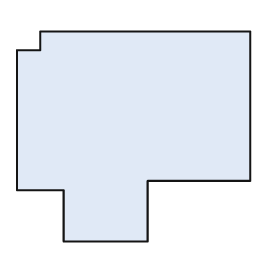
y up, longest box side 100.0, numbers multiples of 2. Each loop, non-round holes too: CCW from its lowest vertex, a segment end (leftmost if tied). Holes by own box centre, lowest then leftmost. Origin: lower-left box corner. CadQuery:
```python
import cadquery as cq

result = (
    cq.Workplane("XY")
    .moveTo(20.0, 0.0)
    .lineTo(56.0, 0.0)
    .lineTo(56.0, 26.0)
    .lineTo(100.0, 26.0)
    .lineTo(100.0, 90.0)
    .lineTo(10.0, 90.0)
    .lineTo(10.0, 82.0)
    .lineTo(0.0, 82.0)
    .lineTo(0.0, 22.0)
    .lineTo(20.0, 22.0)
    .close()
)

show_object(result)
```